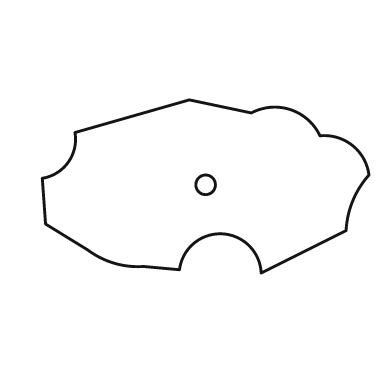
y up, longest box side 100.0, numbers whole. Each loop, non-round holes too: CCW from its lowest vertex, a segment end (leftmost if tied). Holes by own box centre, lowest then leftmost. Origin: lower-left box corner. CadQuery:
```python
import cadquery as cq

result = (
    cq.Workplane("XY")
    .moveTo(67.0, 0.0)
    .lineTo(93.0, 13.0)
    .threePointArc((95.0, 22.0), (100.0, 30.0))
    .threePointArc((95.0, 39.0), (85.0, 42.0))
    .threePointArc((76.0, 50.0), (64.0, 49.0))
    .lineTo(45.0, 53.0)
    .lineTo(10.0, 43.0)
    .threePointArc((8.0, 34.0), (0.0, 29.0))
    .lineTo(1.0, 15.0)
    .lineTo(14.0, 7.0)
    .threePointArc((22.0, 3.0), (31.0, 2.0))
    .lineTo(42.0, 1.0)
    .threePointArc((55.0, 12.0), (67.0, 0.0))
    .close()
    .moveTo(50.0, 27.0)
    .circle(3.0)
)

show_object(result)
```